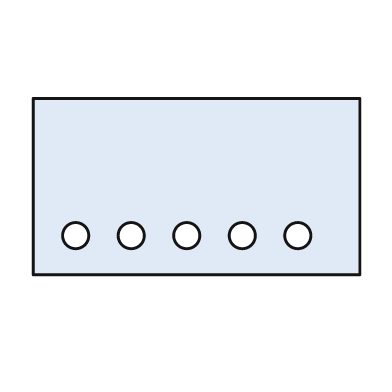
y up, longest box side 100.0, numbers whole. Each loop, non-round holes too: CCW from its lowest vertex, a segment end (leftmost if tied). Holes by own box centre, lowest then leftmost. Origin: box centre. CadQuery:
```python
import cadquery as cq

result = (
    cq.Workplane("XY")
    .moveTo(-50.0, -27.0)
    .lineTo(50.0, -27.0)
    .lineTo(50.0, 27.0)
    .lineTo(-50.0, 27.0)
    .close()
    .moveTo(-37.0, -15.0)
    .circle(4.0)
    .moveTo(-20.0, -15.0)
    .circle(4.0)
    .moveTo(-3.0, -15.0)
    .circle(4.0)
    .moveTo(14.0, -15.0)
    .circle(4.0)
    .moveTo(31.0, -15.0)
    .circle(4.0)
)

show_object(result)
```